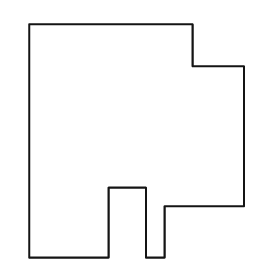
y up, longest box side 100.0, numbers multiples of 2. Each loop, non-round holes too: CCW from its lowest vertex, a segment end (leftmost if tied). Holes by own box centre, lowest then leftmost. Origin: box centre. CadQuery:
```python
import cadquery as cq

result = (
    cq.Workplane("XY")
    .moveTo(-46.0, -50.0)
    .lineTo(-12.0, -50.0)
    .lineTo(-12.0, -20.0)
    .lineTo(4.0, -20.0)
    .lineTo(4.0, -50.0)
    .lineTo(12.0, -50.0)
    .lineTo(12.0, -28.0)
    .lineTo(46.0, -28.0)
    .lineTo(46.0, 32.0)
    .lineTo(24.0, 32.0)
    .lineTo(24.0, 50.0)
    .lineTo(-46.0, 50.0)
    .close()
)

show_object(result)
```